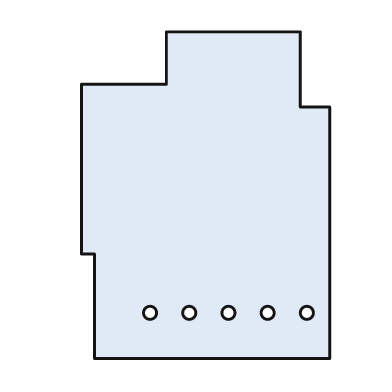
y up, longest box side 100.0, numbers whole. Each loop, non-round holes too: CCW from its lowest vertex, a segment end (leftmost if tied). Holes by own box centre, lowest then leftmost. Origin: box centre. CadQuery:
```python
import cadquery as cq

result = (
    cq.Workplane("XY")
    .moveTo(-34.0, -50.0)
    .lineTo(38.0, -50.0)
    .lineTo(38.0, 27.0)
    .lineTo(29.0, 27.0)
    .lineTo(29.0, 50.0)
    .lineTo(-12.0, 50.0)
    .lineTo(-12.0, 34.0)
    .lineTo(-38.0, 34.0)
    .lineTo(-38.0, -18.0)
    .lineTo(-34.0, -18.0)
    .close()
    .moveTo(-17.0, -36.0)
    .circle(2.0)
    .moveTo(-5.0, -36.0)
    .circle(2.0)
    .moveTo(7.0, -36.0)
    .circle(2.0)
    .moveTo(19.0, -36.0)
    .circle(2.0)
    .moveTo(31.0, -36.0)
    .circle(2.0)
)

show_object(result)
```